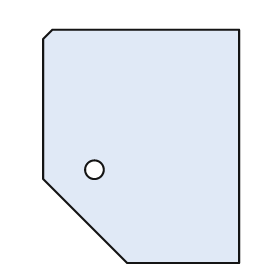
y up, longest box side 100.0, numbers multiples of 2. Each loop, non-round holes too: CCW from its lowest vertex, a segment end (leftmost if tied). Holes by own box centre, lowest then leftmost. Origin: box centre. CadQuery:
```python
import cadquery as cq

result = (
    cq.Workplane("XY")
    .moveTo(-6.0, -50.0)
    .lineTo(42.0, -50.0)
    .lineTo(42.0, 50.0)
    .lineTo(-38.0, 50.0)
    .lineTo(-42.0, 46.0)
    .lineTo(-42.0, -14.0)
    .close()
    .moveTo(-20.0, -10.0)
    .circle(4.0)
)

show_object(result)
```